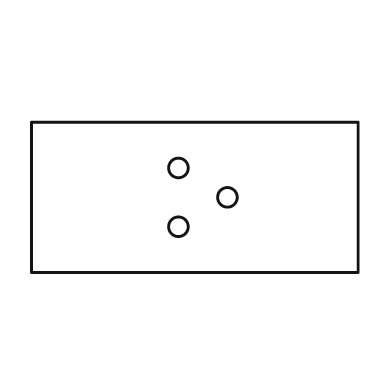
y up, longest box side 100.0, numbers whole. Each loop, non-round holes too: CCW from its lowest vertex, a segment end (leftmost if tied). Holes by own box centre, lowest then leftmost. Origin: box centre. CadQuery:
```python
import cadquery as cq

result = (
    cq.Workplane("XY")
    .moveTo(-50.0, -23.0)
    .lineTo(50.0, -23.0)
    .lineTo(50.0, 23.0)
    .lineTo(-50.0, 23.0)
    .close()
    .moveTo(-5.0, -9.0)
    .circle(3.0)
    .moveTo(10.0, 0.0)
    .circle(3.0)
    .moveTo(-5.0, 9.0)
    .circle(3.0)
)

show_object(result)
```